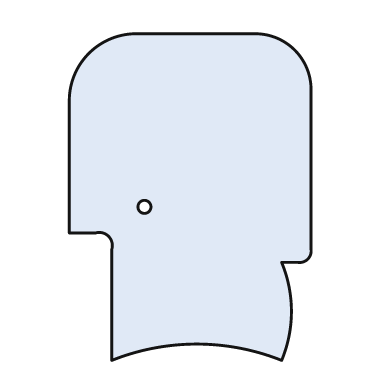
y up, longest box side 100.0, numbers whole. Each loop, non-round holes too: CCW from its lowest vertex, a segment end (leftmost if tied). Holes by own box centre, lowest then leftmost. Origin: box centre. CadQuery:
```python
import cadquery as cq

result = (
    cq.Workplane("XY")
    .moveTo(-24.0, -50.0)
    .threePointArc((2.0, -45.0), (28.0, -50.0))
    .threePointArc((31.0, -35.0), (28.0, -20.0))
    .lineTo(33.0, -20.0)
    .threePointArc((36.0, -19.0), (37.0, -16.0))
    .lineTo(37.0, 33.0)
    .threePointArc((32.0, 45.0), (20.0, 50.0))
    .lineTo(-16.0, 50.0)
    .threePointArc((-31.0, 44.0), (-37.0, 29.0))
    .lineTo(-37.0, -11.0)
    .lineTo(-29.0, -11.0)
    .threePointArc((-25.0, -12.0), (-24.0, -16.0))
    .close()
    .moveTo(-14.0, -3.0)
    .circle(2.0)
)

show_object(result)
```